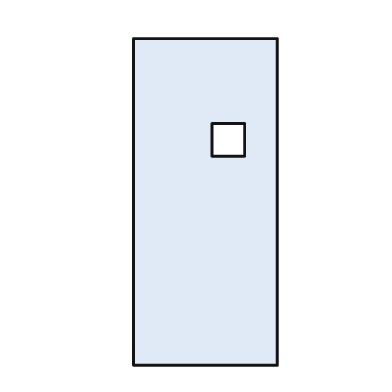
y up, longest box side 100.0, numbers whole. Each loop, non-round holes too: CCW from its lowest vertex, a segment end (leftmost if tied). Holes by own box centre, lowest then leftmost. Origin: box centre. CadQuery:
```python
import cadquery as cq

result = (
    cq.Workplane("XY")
    .moveTo(-22.0, -50.0)
    .lineTo(22.0, -50.0)
    .lineTo(22.0, 50.0)
    .lineTo(-22.0, 50.0)
    .close()
    .moveTo(2.0, 14.0)
    .lineTo(12.0, 14.0)
    .lineTo(12.0, 24.0)
    .lineTo(2.0, 24.0)
    .close()
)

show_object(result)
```